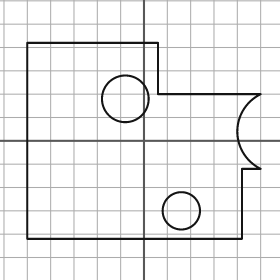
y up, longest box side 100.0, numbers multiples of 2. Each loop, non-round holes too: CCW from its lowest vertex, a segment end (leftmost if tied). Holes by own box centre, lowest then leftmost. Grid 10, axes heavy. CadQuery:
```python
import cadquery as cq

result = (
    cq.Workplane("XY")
    .moveTo(-50.0, -42.0)
    .lineTo(42.0, -42.0)
    .lineTo(42.0, -12.0)
    .lineTo(50.0, -12.0)
    .threePointArc((40.0, 4.0), (50.0, 20.0))
    .lineTo(6.0, 20.0)
    .lineTo(6.0, 42.0)
    .lineTo(-50.0, 42.0)
    .close()
    .moveTo(16.0, -30.0)
    .circle(8.0)
    .moveTo(-8.0, 18.0)
    .circle(10.0)
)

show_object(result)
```